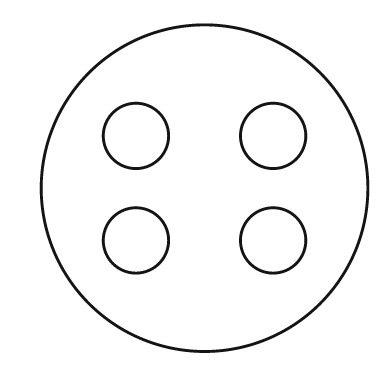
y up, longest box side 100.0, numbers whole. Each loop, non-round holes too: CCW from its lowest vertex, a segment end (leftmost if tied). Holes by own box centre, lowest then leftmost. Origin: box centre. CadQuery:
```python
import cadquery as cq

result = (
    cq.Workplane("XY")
    .moveTo(0.0, 0.0)
    .circle(50.0)
    .moveTo(-21.0, -16.0)
    .circle(10.0)
    .moveTo(21.0, -16.0)
    .circle(10.0)
    .moveTo(-21.0, 16.0)
    .circle(10.0)
    .moveTo(21.0, 16.0)
    .circle(10.0)
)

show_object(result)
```